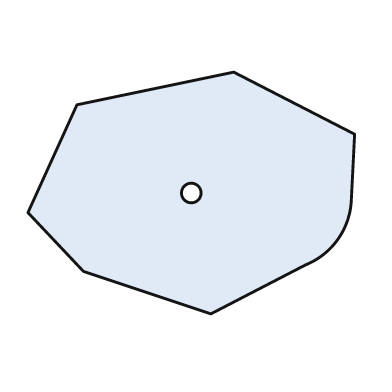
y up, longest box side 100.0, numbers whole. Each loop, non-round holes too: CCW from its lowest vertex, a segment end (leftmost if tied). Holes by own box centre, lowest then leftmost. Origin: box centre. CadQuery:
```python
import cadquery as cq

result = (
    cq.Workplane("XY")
    .moveTo(6.0, -37.0)
    .lineTo(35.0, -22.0)
    .threePointArc((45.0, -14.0), (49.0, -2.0))
    .lineTo(50.0, 18.0)
    .lineTo(13.0, 37.0)
    .lineTo(-35.0, 27.0)
    .lineTo(-50.0, -6.0)
    .lineTo(-33.0, -24.0)
    .close()
    .moveTo(0.0, 0.0)
    .circle(3.0)
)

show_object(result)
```